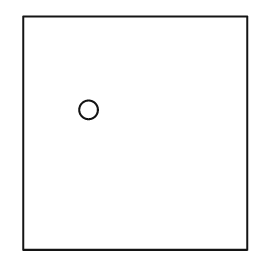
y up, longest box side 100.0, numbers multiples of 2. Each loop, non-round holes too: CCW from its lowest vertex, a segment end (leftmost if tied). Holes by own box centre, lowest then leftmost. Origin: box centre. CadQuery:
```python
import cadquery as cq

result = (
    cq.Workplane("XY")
    .moveTo(-48.0, -50.0)
    .lineTo(48.0, -50.0)
    .lineTo(48.0, 50.0)
    .lineTo(-48.0, 50.0)
    .close()
    .moveTo(-20.0, 10.0)
    .circle(4.0)
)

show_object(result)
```